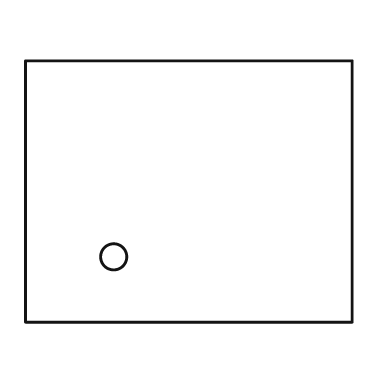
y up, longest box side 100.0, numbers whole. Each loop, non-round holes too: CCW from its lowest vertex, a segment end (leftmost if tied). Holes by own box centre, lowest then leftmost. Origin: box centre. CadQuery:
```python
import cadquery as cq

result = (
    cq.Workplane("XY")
    .moveTo(-50.0, -40.0)
    .lineTo(50.0, -40.0)
    .lineTo(50.0, 40.0)
    .lineTo(-50.0, 40.0)
    .close()
    .moveTo(-23.0, -20.0)
    .circle(4.0)
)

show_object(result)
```